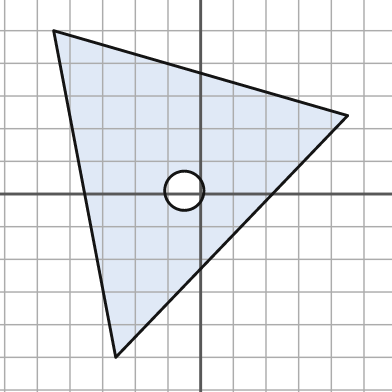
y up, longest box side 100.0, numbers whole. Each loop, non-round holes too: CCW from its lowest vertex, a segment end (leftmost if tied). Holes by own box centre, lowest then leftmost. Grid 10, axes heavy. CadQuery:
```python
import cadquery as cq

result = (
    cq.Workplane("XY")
    .moveTo(-26.0, -50.0)
    .lineTo(45.0, 24.0)
    .lineTo(-45.0, 50.0)
    .close()
    .moveTo(-5.0, 1.0)
    .circle(6.0)
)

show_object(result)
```